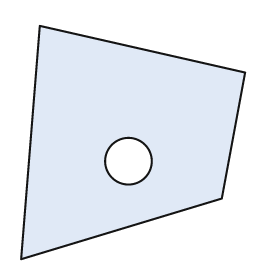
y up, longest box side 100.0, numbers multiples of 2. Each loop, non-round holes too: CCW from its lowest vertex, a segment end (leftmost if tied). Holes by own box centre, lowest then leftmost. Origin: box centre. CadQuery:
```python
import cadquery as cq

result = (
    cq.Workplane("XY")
    .moveTo(-48.0, -50.0)
    .lineTo(38.0, -24.0)
    .lineTo(48.0, 30.0)
    .lineTo(-40.0, 50.0)
    .close()
    .moveTo(-2.0, -8.0)
    .circle(10.0)
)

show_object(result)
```